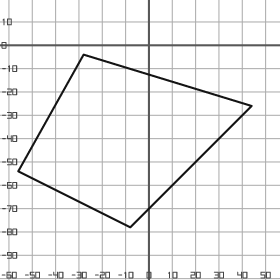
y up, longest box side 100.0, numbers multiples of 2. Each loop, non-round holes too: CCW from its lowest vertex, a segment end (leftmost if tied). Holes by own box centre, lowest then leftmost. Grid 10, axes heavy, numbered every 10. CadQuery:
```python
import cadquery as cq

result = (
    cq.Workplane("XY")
    .moveTo(-8.0, -78.0)
    .lineTo(44.0, -26.0)
    .lineTo(-28.0, -4.0)
    .lineTo(-56.0, -54.0)
    .close()
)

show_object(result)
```